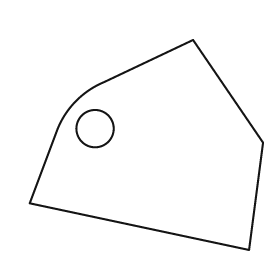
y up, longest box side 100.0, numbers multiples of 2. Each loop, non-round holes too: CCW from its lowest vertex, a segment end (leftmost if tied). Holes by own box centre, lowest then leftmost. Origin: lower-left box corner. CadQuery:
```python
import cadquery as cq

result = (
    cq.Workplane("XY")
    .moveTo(94.0, 0.0)
    .lineTo(100.0, 46.0)
    .lineTo(70.0, 90.0)
    .lineTo(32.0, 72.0)
    .threePointArc((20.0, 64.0), (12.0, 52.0))
    .lineTo(0.0, 20.0)
    .close()
    .moveTo(28.0, 52.0)
    .circle(8.0)
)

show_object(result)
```